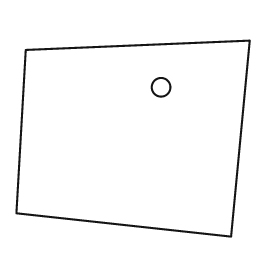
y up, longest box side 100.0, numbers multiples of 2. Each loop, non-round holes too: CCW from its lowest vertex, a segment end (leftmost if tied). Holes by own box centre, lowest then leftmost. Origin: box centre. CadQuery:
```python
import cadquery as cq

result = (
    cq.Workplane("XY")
    .moveTo(42.0, -42.0)
    .lineTo(50.0, 42.0)
    .lineTo(-46.0, 38.0)
    .lineTo(-50.0, -32.0)
    .close()
    .moveTo(12.0, 22.0)
    .circle(4.0)
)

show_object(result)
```